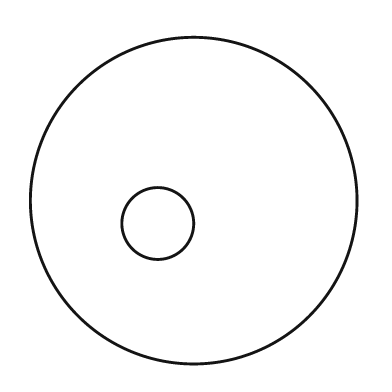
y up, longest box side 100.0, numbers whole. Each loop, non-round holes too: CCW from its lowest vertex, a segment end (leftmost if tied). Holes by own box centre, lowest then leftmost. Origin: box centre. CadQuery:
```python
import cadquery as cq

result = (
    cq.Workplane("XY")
    .moveTo(0.0, 0.0)
    .circle(50.0)
    .moveTo(-11.0, -7.0)
    .circle(11.0)
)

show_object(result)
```